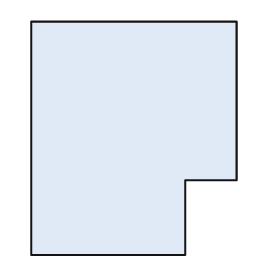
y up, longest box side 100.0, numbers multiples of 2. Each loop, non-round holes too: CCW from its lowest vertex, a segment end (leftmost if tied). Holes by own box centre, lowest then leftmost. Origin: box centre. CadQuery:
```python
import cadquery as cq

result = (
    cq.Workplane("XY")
    .moveTo(-44.0, -50.0)
    .lineTo(22.0, -50.0)
    .lineTo(22.0, -18.0)
    .lineTo(44.0, -18.0)
    .lineTo(44.0, 50.0)
    .lineTo(-44.0, 50.0)
    .close()
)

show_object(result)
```